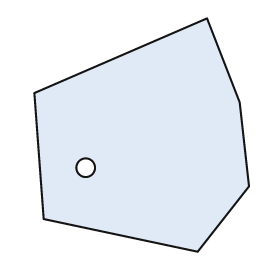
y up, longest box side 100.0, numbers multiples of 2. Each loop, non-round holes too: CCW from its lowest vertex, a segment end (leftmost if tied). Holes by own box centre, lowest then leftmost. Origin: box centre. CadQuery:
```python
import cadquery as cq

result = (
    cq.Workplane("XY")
    .moveTo(24.0, -50.0)
    .lineTo(46.0, -22.0)
    .lineTo(42.0, 14.0)
    .lineTo(28.0, 50.0)
    .lineTo(-46.0, 18.0)
    .lineTo(-42.0, -36.0)
    .close()
    .moveTo(-24.0, -14.0)
    .circle(4.0)
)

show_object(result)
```